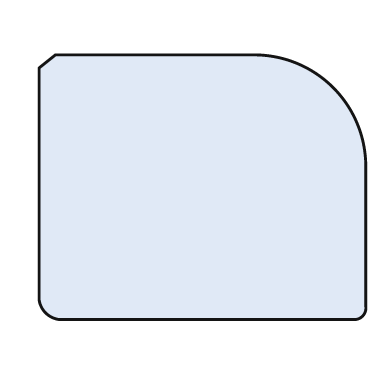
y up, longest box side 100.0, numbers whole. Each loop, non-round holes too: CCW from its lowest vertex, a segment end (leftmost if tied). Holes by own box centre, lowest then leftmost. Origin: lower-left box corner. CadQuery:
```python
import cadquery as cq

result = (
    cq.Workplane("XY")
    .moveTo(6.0, 0.0)
    .lineTo(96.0, 0.0)
    .threePointArc((99.0, 1.0), (100.0, 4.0))
    .lineTo(100.0, 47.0)
    .threePointArc((90.0, 71.0), (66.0, 81.0))
    .lineTo(5.0, 81.0)
    .lineTo(0.0, 77.0)
    .lineTo(0.0, 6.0)
    .threePointArc((2.0, 2.0), (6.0, 0.0))
    .close()
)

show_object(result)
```